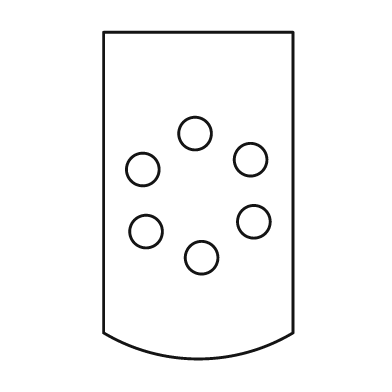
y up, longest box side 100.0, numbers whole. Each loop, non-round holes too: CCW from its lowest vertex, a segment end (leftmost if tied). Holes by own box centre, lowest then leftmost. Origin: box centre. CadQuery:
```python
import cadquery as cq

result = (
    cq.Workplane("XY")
    .moveTo(-29.0, -42.0)
    .threePointArc((0.0, -50.0), (29.0, -42.0))
    .lineTo(29.0, 50.0)
    .lineTo(-29.0, 50.0)
    .close()
    .moveTo(1.0, -19.0)
    .circle(5.0)
    .moveTo(-16.0, -11.0)
    .circle(5.0)
    .moveTo(17.0, -8.0)
    .circle(5.0)
    .moveTo(-17.0, 8.0)
    .circle(5.0)
    .moveTo(16.0, 11.0)
    .circle(5.0)
    .moveTo(-1.0, 19.0)
    .circle(5.0)
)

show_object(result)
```